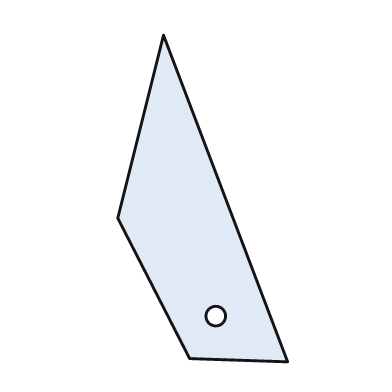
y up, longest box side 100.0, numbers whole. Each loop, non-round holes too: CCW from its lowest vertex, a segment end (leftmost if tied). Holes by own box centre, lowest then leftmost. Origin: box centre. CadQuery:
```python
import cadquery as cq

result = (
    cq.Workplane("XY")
    .moveTo(26.0, -50.0)
    .lineTo(-12.0, 50.0)
    .lineTo(-26.0, -6.0)
    .lineTo(-4.0, -49.0)
    .close()
    .moveTo(4.0, -36.0)
    .circle(3.0)
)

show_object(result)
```